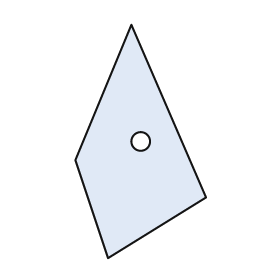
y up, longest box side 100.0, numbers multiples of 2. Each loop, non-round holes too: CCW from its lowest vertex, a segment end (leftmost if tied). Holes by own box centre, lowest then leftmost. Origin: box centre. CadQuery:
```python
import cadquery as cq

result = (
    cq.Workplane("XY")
    .moveTo(-14.0, -50.0)
    .lineTo(28.0, -24.0)
    .lineTo(-4.0, 50.0)
    .lineTo(-28.0, -8.0)
    .close()
    .moveTo(0.0, 0.0)
    .circle(4.0)
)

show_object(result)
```